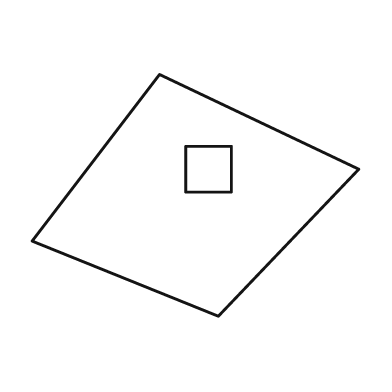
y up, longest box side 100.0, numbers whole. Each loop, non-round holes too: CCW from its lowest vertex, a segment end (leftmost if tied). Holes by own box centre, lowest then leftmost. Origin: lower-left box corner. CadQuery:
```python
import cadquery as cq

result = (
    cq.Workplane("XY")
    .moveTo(57.0, 0.0)
    .lineTo(100.0, 45.0)
    .lineTo(39.0, 74.0)
    .lineTo(0.0, 23.0)
    .close()
    .moveTo(47.0, 38.0)
    .lineTo(61.0, 38.0)
    .lineTo(61.0, 52.0)
    .lineTo(47.0, 52.0)
    .close()
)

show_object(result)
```